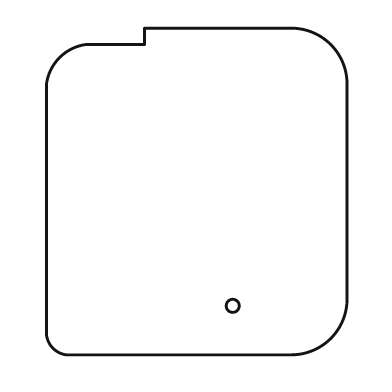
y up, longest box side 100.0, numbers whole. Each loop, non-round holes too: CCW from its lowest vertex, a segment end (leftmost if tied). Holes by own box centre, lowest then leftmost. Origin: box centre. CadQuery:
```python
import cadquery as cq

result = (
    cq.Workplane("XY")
    .moveTo(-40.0, -50.0)
    .lineTo(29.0, -50.0)
    .threePointArc((41.0, -45.0), (46.0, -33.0))
    .lineTo(46.0, 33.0)
    .threePointArc((41.0, 45.0), (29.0, 50.0))
    .lineTo(-16.0, 50.0)
    .lineTo(-16.0, 45.0)
    .lineTo(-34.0, 45.0)
    .threePointArc((-42.0, 41.0), (-46.0, 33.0))
    .lineTo(-46.0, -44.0)
    .threePointArc((-44.0, -48.0), (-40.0, -50.0))
    .close()
    .moveTo(11.0, -35.0)
    .circle(2.0)
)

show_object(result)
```